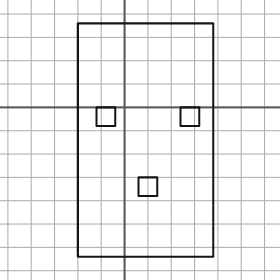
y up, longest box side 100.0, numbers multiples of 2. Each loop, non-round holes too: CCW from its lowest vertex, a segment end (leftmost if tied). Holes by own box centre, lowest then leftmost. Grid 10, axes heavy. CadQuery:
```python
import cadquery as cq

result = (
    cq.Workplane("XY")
    .moveTo(-20.0, -64.0)
    .lineTo(38.0, -64.0)
    .lineTo(38.0, 36.0)
    .lineTo(-20.0, 36.0)
    .close()
    .moveTo(6.0, -38.0)
    .lineTo(14.0, -38.0)
    .lineTo(14.0, -30.0)
    .lineTo(6.0, -30.0)
    .close()
    .moveTo(-12.0, -8.0)
    .lineTo(-4.0, -8.0)
    .lineTo(-4.0, 0.0)
    .lineTo(-12.0, 0.0)
    .close()
    .moveTo(24.0, -8.0)
    .lineTo(32.0, -8.0)
    .lineTo(32.0, 0.0)
    .lineTo(24.0, 0.0)
    .close()
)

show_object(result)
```